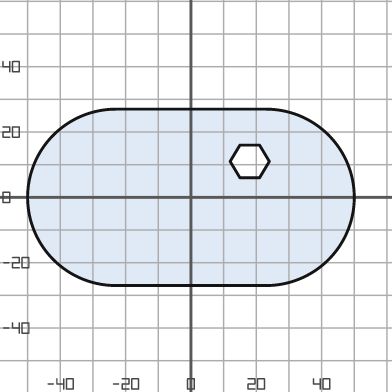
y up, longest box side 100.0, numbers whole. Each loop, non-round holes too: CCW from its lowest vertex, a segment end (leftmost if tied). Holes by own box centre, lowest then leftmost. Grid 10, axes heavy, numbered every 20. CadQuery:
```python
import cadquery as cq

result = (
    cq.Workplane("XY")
    .moveTo(-23.0, -27.0)
    .lineTo(23.0, -27.0)
    .threePointArc((50.0, 0.0), (23.0, 27.0))
    .lineTo(-23.0, 27.0)
    .threePointArc((-50.0, 0.0), (-23.0, -27.0))
    .close()
    .moveTo(15.0, 6.0)
    .lineTo(21.0, 6.0)
    .lineTo(24.0, 11.0)
    .lineTo(21.0, 16.0)
    .lineTo(15.0, 16.0)
    .lineTo(12.0, 11.0)
    .close()
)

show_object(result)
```